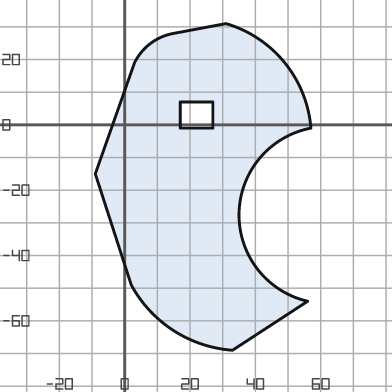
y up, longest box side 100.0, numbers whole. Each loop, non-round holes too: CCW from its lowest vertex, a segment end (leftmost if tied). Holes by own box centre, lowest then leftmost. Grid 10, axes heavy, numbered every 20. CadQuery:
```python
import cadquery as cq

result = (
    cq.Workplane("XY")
    .moveTo(33.0, -69.0)
    .lineTo(56.0, -54.0)
    .threePointArc((35.0, -27.0), (57.0, -1.0))
    .threePointArc((49.0, 19.0), (31.0, 31.0))
    .lineTo(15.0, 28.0)
    .threePointArc((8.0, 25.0), (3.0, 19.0))
    .lineTo(-9.0, -15.0)
    .lineTo(2.0, -49.0)
    .threePointArc((15.0, -63.0), (33.0, -69.0))
    .close()
    .moveTo(17.0, -1.0)
    .lineTo(27.0, -1.0)
    .lineTo(27.0, 7.0)
    .lineTo(17.0, 7.0)
    .close()
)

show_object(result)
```